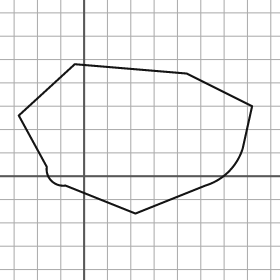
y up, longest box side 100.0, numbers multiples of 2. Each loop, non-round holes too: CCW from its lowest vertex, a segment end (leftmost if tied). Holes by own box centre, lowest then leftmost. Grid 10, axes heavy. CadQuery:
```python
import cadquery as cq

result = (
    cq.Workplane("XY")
    .moveTo(22.0, -16.0)
    .lineTo(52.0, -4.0)
    .threePointArc((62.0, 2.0), (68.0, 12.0))
    .lineTo(72.0, 30.0)
    .lineTo(44.0, 44.0)
    .lineTo(-4.0, 48.0)
    .lineTo(-28.0, 26.0)
    .lineTo(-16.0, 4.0)
    .threePointArc((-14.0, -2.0), (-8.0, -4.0))
    .close()
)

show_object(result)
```